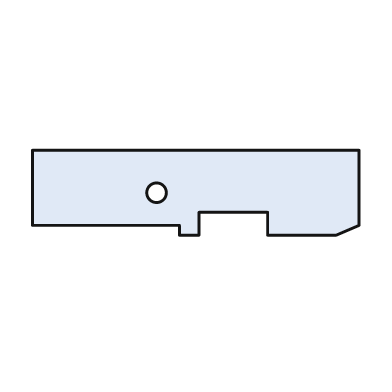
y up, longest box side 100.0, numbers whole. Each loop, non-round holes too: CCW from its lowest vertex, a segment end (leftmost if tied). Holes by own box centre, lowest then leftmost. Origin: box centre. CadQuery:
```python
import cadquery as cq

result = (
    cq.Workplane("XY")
    .moveTo(-5.0, -13.0)
    .lineTo(1.0, -13.0)
    .lineTo(1.0, -6.0)
    .lineTo(22.0, -6.0)
    .lineTo(22.0, -13.0)
    .lineTo(43.0, -13.0)
    .lineTo(50.0, -10.0)
    .lineTo(50.0, 13.0)
    .lineTo(-50.0, 13.0)
    .lineTo(-50.0, -10.0)
    .lineTo(-5.0, -10.0)
    .close()
    .moveTo(-12.0, 0.0)
    .circle(3.0)
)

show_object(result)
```